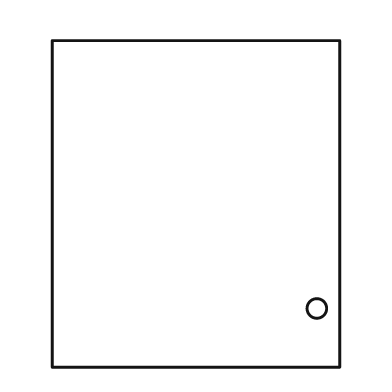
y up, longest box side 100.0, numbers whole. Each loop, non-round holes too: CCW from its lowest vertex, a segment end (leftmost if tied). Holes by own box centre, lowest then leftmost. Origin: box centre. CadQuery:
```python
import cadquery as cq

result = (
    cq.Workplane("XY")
    .moveTo(-44.0, -50.0)
    .lineTo(44.0, -50.0)
    .lineTo(44.0, 50.0)
    .lineTo(-44.0, 50.0)
    .close()
    .moveTo(37.0, -32.0)
    .circle(3.0)
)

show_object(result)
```